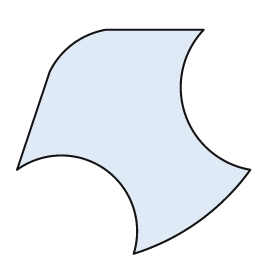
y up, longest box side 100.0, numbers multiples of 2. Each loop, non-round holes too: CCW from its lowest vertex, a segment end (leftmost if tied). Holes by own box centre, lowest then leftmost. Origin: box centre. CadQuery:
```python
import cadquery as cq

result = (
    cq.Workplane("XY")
    .moveTo(0.0, -48.0)
    .threePointArc((28.0, -34.0), (50.0, -12.0))
    .threePointArc((22.0, 12.0), (30.0, 48.0))
    .lineTo(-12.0, 48.0)
    .threePointArc((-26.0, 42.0), (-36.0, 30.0))
    .lineTo(-50.0, -12.0)
    .threePointArc((-12.0, -12.0), (0.0, -48.0))
    .close()
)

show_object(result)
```